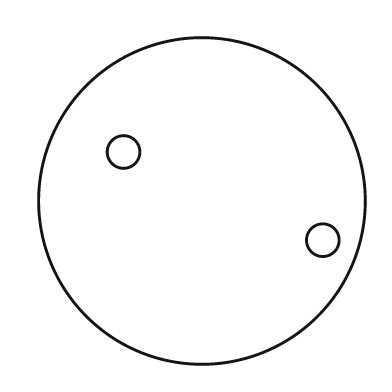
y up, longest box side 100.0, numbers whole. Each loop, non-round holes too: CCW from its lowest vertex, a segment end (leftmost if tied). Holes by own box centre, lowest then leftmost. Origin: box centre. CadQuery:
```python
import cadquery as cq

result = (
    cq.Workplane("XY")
    .moveTo(0.0, 0.0)
    .circle(50.0)
    .moveTo(37.0, -12.0)
    .circle(5.0)
    .moveTo(-24.0, 15.0)
    .circle(5.0)
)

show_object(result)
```